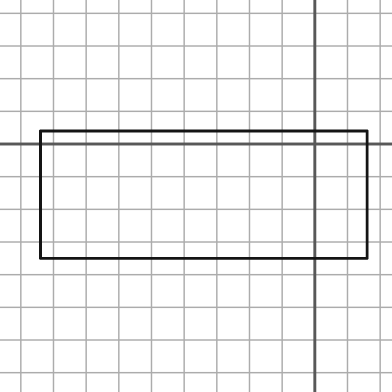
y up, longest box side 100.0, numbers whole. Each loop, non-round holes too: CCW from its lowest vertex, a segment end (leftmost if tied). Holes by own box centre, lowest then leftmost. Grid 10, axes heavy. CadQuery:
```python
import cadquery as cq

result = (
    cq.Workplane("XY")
    .moveTo(-84.0, -35.0)
    .lineTo(16.0, -35.0)
    .lineTo(16.0, 4.0)
    .lineTo(-84.0, 4.0)
    .close()
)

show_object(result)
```